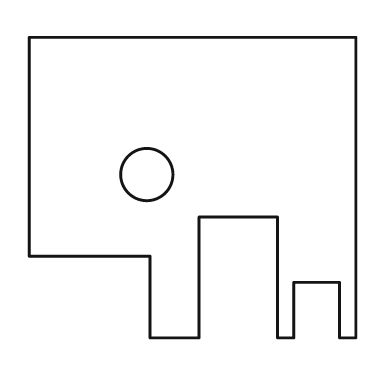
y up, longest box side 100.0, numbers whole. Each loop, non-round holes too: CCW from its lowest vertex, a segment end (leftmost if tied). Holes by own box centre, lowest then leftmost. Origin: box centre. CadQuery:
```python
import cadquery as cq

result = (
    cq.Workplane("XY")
    .moveTo(-13.0, -46.0)
    .lineTo(2.0, -46.0)
    .lineTo(2.0, -9.0)
    .lineTo(26.0, -9.0)
    .lineTo(26.0, -46.0)
    .lineTo(31.0, -46.0)
    .lineTo(31.0, -29.0)
    .lineTo(45.0, -29.0)
    .lineTo(45.0, -46.0)
    .lineTo(50.0, -46.0)
    .lineTo(50.0, 46.0)
    .lineTo(-50.0, 46.0)
    .lineTo(-50.0, -21.0)
    .lineTo(-13.0, -21.0)
    .close()
    .moveTo(-14.0, 4.0)
    .circle(8.0)
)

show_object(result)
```